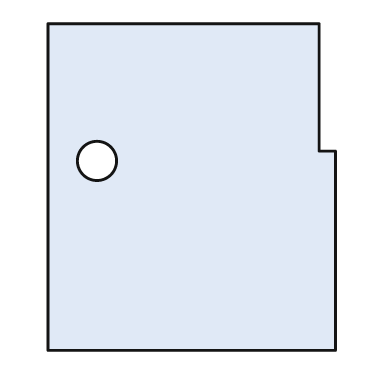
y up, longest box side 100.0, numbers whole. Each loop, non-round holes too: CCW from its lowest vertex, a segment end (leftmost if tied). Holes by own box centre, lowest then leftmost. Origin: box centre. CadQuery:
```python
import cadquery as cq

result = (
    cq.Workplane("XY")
    .moveTo(-44.0, -50.0)
    .lineTo(44.0, -50.0)
    .lineTo(44.0, 11.0)
    .lineTo(39.0, 11.0)
    .lineTo(39.0, 50.0)
    .lineTo(-44.0, 50.0)
    .close()
    .moveTo(-29.0, 8.0)
    .circle(6.0)
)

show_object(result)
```